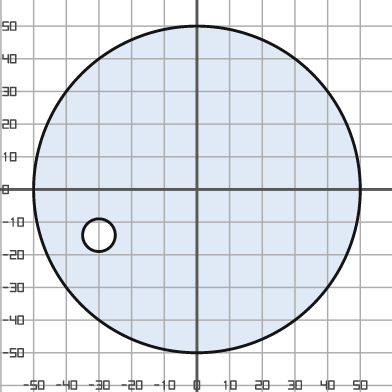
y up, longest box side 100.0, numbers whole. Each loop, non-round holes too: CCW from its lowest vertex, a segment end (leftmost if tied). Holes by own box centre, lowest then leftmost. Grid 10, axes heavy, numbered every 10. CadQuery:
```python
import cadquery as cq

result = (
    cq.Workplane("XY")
    .moveTo(0.0, 0.0)
    .circle(50.0)
    .moveTo(-30.0, -14.0)
    .circle(5.0)
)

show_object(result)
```